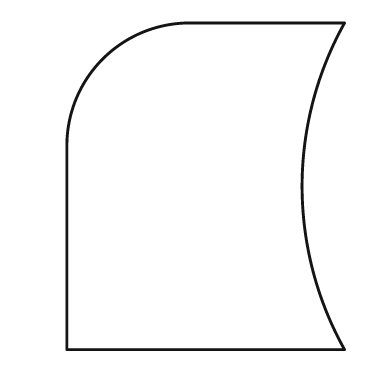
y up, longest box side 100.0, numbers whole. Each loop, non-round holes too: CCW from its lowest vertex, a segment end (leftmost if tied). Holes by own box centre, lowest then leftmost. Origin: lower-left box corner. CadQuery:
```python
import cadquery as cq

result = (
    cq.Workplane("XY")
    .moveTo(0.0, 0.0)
    .lineTo(85.0, 0.0)
    .threePointArc((72.0, 50.0), (85.0, 100.0))
    .lineTo(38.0, 100.0)
    .threePointArc((11.0, 89.0), (0.0, 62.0))
    .close()
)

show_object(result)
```